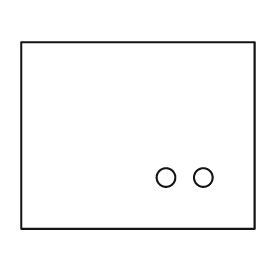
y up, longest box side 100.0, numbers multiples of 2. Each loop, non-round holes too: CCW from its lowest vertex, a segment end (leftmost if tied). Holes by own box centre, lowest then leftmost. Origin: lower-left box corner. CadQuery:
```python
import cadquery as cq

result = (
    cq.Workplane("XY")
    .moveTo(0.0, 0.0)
    .lineTo(100.0, 0.0)
    .lineTo(100.0, 80.0)
    .lineTo(0.0, 80.0)
    .close()
    .moveTo(62.0, 22.0)
    .circle(4.0)
    .moveTo(78.0, 22.0)
    .circle(4.0)
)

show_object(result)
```